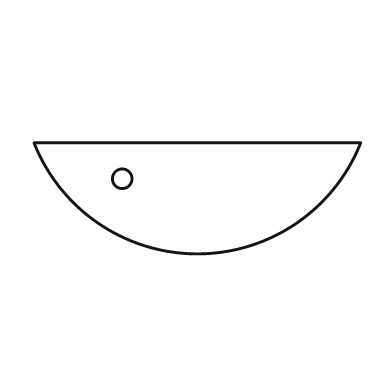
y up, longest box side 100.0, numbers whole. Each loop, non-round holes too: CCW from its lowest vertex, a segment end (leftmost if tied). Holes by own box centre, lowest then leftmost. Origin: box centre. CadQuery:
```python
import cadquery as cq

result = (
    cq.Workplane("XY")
    .moveTo(-50.0, 17.0)
    .threePointArc((0.0, -17.0), (50.0, 17.0))
    .close()
    .moveTo(-23.0, 6.0)
    .circle(3.0)
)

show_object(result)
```